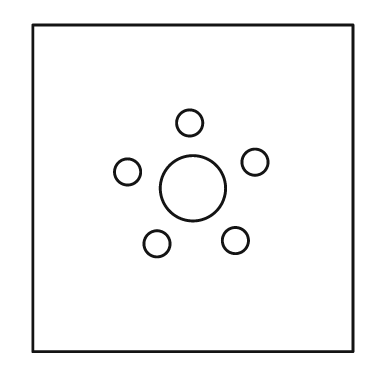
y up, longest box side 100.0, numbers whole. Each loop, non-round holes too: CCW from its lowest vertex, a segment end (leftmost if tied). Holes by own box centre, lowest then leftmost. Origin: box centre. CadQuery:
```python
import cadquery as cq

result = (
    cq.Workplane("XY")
    .moveTo(-49.0, -50.0)
    .lineTo(49.0, -50.0)
    .lineTo(49.0, 50.0)
    .lineTo(-49.0, 50.0)
    .close()
    .moveTo(-11.0, -17.0)
    .circle(4.0)
    .moveTo(13.0, -16.0)
    .circle(4.0)
    .moveTo(0.0, 0.0)
    .circle(10.0)
    .moveTo(-20.0, 5.0)
    .circle(4.0)
    .moveTo(19.0, 8.0)
    .circle(4.0)
    .moveTo(-1.0, 20.0)
    .circle(4.0)
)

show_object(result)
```